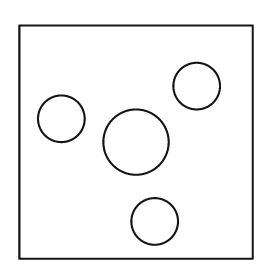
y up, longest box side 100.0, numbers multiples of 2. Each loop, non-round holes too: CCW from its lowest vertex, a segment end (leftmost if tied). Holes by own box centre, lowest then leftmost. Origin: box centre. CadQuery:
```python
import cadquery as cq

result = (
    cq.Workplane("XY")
    .moveTo(-50.0, -50.0)
    .lineTo(50.0, -50.0)
    .lineTo(50.0, 50.0)
    .lineTo(-50.0, 50.0)
    .close()
    .moveTo(8.0, -34.0)
    .circle(10.0)
    .moveTo(0.0, 0.0)
    .circle(14.0)
    .moveTo(-32.0, 10.0)
    .circle(10.0)
    .moveTo(26.0, 24.0)
    .circle(10.0)
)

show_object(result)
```